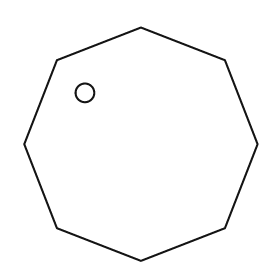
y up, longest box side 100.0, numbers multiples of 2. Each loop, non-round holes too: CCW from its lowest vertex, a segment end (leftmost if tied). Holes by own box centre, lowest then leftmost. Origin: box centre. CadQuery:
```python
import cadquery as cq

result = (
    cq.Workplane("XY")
    .moveTo(0.0, -50.0)
    .lineTo(36.0, -36.0)
    .lineTo(50.0, 0.0)
    .lineTo(36.0, 36.0)
    .lineTo(0.0, 50.0)
    .lineTo(-36.0, 36.0)
    .lineTo(-50.0, 0.0)
    .lineTo(-36.0, -36.0)
    .close()
    .moveTo(-24.0, 22.0)
    .circle(4.0)
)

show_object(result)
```